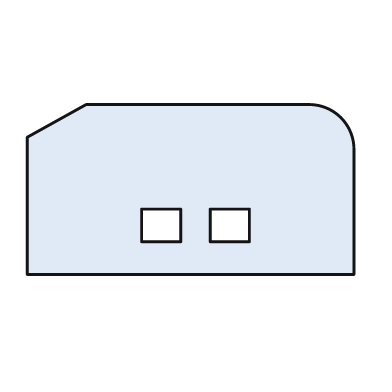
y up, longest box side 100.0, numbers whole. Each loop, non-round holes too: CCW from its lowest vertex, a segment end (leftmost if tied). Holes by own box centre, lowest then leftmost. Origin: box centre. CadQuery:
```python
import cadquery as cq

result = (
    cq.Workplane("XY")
    .moveTo(-50.0, -26.0)
    .lineTo(50.0, -26.0)
    .lineTo(50.0, 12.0)
    .threePointArc((46.0, 22.0), (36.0, 26.0))
    .lineTo(-32.0, 26.0)
    .lineTo(-50.0, 16.0)
    .close()
    .moveTo(-15.0, -16.0)
    .lineTo(-3.0, -16.0)
    .lineTo(-3.0, -6.0)
    .lineTo(-15.0, -6.0)
    .close()
    .moveTo(6.0, -16.0)
    .lineTo(18.0, -16.0)
    .lineTo(18.0, -6.0)
    .lineTo(6.0, -6.0)
    .close()
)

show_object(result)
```